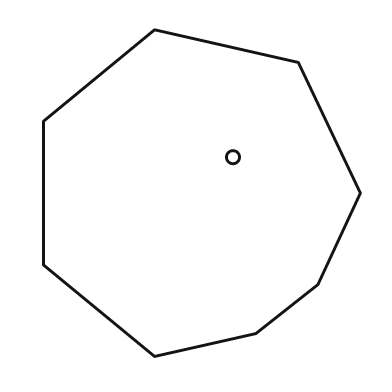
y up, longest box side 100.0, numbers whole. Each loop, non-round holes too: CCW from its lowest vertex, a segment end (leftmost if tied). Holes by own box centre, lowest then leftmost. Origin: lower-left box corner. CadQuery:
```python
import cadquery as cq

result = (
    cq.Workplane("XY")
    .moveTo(34.0, 0.0)
    .lineTo(65.0, 7.0)
    .lineTo(84.0, 22.0)
    .lineTo(97.0, 50.0)
    .lineTo(78.0, 90.0)
    .lineTo(34.0, 100.0)
    .lineTo(0.0, 72.0)
    .lineTo(0.0, 28.0)
    .close()
    .moveTo(58.0, 61.0)
    .circle(2.0)
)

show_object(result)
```